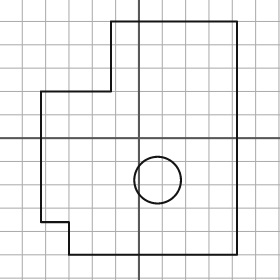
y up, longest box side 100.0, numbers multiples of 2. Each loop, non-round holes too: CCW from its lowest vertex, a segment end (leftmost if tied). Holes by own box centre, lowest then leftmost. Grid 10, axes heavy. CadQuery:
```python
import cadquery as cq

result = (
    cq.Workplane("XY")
    .moveTo(-30.0, -50.0)
    .lineTo(42.0, -50.0)
    .lineTo(42.0, 50.0)
    .lineTo(-12.0, 50.0)
    .lineTo(-12.0, 20.0)
    .lineTo(-42.0, 20.0)
    .lineTo(-42.0, -36.0)
    .lineTo(-30.0, -36.0)
    .close()
    .moveTo(8.0, -18.0)
    .circle(10.0)
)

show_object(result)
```